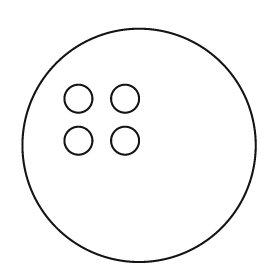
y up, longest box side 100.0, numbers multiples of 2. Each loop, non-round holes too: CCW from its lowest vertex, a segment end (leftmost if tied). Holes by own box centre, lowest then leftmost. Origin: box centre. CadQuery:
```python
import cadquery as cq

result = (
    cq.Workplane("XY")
    .moveTo(0.0, 0.0)
    .circle(50.0)
    .moveTo(-26.0, 2.0)
    .circle(6.0)
    .moveTo(-6.0, 2.0)
    .circle(6.0)
    .moveTo(-26.0, 20.0)
    .circle(6.0)
    .moveTo(-6.0, 20.0)
    .circle(6.0)
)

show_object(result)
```